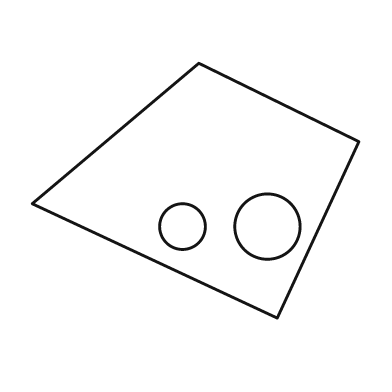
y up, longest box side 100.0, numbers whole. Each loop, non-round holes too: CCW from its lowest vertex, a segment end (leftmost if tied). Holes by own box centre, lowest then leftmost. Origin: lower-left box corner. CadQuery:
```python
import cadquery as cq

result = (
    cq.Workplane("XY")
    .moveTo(75.0, 0.0)
    .lineTo(100.0, 54.0)
    .lineTo(51.0, 78.0)
    .lineTo(0.0, 35.0)
    .close()
    .moveTo(46.0, 28.0)
    .circle(7.0)
    .moveTo(72.0, 28.0)
    .circle(10.0)
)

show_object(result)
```